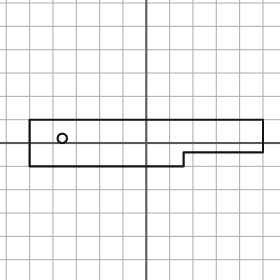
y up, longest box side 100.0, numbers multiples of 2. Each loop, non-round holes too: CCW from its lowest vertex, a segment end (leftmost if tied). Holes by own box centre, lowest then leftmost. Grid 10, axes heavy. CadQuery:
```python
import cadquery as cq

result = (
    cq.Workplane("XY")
    .moveTo(-50.0, -10.0)
    .lineTo(16.0, -10.0)
    .lineTo(16.0, -4.0)
    .lineTo(50.0, -4.0)
    .lineTo(50.0, 10.0)
    .lineTo(-50.0, 10.0)
    .close()
    .moveTo(-36.0, 2.0)
    .circle(2.0)
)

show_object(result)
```